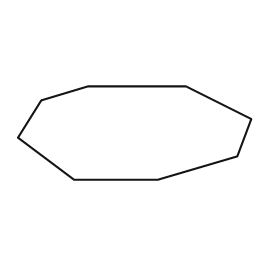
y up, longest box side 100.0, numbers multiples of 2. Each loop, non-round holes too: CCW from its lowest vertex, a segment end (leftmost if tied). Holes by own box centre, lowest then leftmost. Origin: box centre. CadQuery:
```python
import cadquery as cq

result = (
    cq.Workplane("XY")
    .moveTo(-26.0, -20.0)
    .lineTo(10.0, -20.0)
    .lineTo(44.0, -10.0)
    .lineTo(50.0, 6.0)
    .lineTo(22.0, 20.0)
    .lineTo(-20.0, 20.0)
    .lineTo(-40.0, 14.0)
    .lineTo(-50.0, -2.0)
    .close()
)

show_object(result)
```